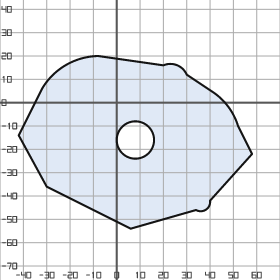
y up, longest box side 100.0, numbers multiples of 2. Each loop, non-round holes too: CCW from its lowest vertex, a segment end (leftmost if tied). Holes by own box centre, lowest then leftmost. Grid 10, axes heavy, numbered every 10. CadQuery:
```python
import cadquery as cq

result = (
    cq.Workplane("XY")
    .moveTo(6.0, -54.0)
    .lineTo(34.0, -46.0)
    .threePointArc((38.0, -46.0), (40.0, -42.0))
    .lineTo(58.0, -22.0)
    .lineTo(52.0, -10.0)
    .threePointArc((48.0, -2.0), (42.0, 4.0))
    .lineTo(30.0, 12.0)
    .threePointArc((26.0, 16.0), (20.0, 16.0))
    .lineTo(-8.0, 20.0)
    .threePointArc((-22.0, 16.0), (-32.0, 6.0))
    .lineTo(-42.0, -14.0)
    .lineTo(-30.0, -36.0)
    .close()
    .moveTo(8.0, -16.0)
    .circle(8.0)
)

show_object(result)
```